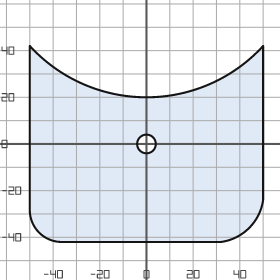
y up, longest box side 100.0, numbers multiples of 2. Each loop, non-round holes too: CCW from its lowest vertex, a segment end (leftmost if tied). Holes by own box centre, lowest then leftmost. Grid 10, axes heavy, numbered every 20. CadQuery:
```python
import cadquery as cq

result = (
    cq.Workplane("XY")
    .moveTo(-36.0, -42.0)
    .lineTo(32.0, -42.0)
    .threePointArc((44.0, -36.0), (50.0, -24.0))
    .lineTo(50.0, 42.0)
    .threePointArc((0.0, 20.0), (-50.0, 42.0))
    .lineTo(-50.0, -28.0)
    .threePointArc((-46.0, -38.0), (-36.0, -42.0))
    .close()
    .moveTo(0.0, 0.0)
    .circle(4.0)
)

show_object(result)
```